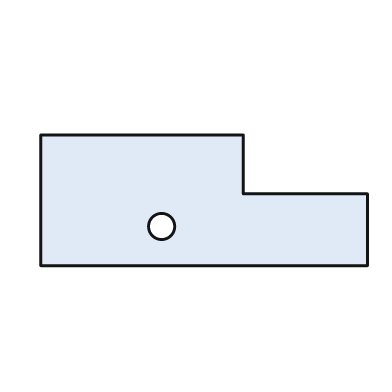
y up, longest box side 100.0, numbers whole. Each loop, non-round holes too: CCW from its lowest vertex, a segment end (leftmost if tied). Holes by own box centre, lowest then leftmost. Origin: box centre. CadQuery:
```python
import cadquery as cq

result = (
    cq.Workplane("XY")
    .moveTo(-50.0, -20.0)
    .lineTo(50.0, -20.0)
    .lineTo(50.0, 2.0)
    .lineTo(12.0, 2.0)
    .lineTo(12.0, 20.0)
    .lineTo(-50.0, 20.0)
    .close()
    .moveTo(-13.0, -8.0)
    .circle(4.0)
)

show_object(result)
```